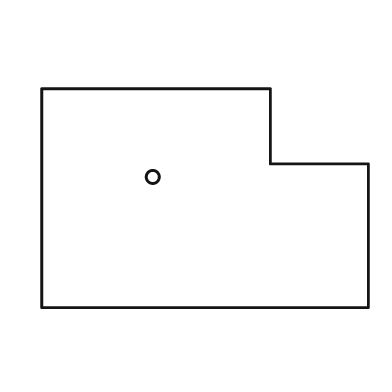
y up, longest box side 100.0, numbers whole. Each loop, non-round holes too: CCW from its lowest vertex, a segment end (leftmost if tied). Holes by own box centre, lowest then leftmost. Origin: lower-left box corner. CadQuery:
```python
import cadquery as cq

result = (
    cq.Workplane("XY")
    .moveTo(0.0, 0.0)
    .lineTo(100.0, 0.0)
    .lineTo(100.0, 44.0)
    .lineTo(70.0, 44.0)
    .lineTo(70.0, 67.0)
    .lineTo(0.0, 67.0)
    .close()
    .moveTo(34.0, 40.0)
    .circle(2.0)
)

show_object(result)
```